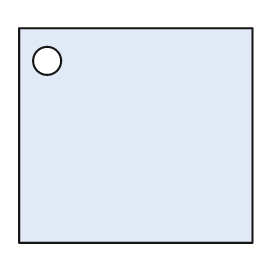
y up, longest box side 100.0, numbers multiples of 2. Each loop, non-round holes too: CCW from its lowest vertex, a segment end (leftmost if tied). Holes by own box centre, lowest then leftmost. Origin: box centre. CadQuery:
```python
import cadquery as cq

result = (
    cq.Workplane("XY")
    .moveTo(-50.0, -46.0)
    .lineTo(50.0, -46.0)
    .lineTo(50.0, 46.0)
    .lineTo(-50.0, 46.0)
    .close()
    .moveTo(-38.0, 32.0)
    .circle(6.0)
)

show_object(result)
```